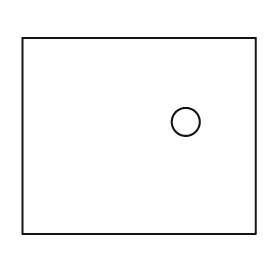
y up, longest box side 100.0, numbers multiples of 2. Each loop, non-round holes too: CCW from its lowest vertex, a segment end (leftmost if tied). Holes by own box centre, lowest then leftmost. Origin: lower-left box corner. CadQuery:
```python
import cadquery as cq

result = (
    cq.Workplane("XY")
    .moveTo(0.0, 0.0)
    .lineTo(100.0, 0.0)
    .lineTo(100.0, 84.0)
    .lineTo(0.0, 84.0)
    .close()
    .moveTo(70.0, 48.0)
    .circle(6.0)
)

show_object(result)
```